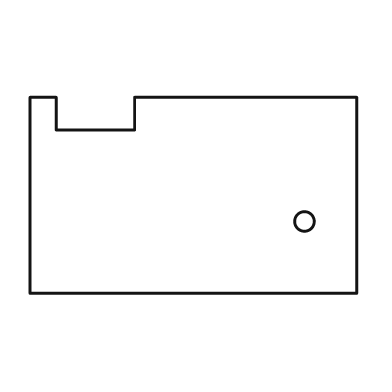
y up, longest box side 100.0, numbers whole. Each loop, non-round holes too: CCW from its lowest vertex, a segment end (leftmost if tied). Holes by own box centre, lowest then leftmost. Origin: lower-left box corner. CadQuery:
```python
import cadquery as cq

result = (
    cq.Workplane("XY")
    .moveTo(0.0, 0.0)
    .lineTo(100.0, 0.0)
    .lineTo(100.0, 60.0)
    .lineTo(32.0, 60.0)
    .lineTo(32.0, 50.0)
    .lineTo(8.0, 50.0)
    .lineTo(8.0, 60.0)
    .lineTo(0.0, 60.0)
    .close()
    .moveTo(84.0, 22.0)
    .circle(3.0)
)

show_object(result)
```